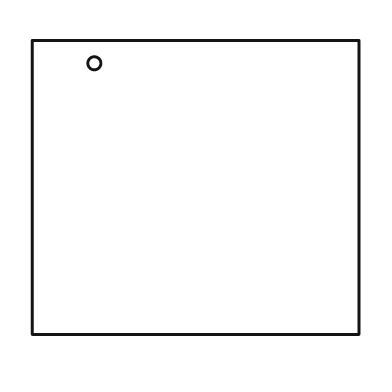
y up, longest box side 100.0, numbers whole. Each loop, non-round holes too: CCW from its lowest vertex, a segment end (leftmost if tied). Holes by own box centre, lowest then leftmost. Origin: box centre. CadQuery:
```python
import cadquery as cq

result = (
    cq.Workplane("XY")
    .moveTo(-50.0, -45.0)
    .lineTo(50.0, -45.0)
    .lineTo(50.0, 45.0)
    .lineTo(-50.0, 45.0)
    .close()
    .moveTo(-31.0, 38.0)
    .circle(2.0)
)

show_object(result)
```